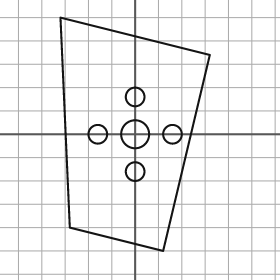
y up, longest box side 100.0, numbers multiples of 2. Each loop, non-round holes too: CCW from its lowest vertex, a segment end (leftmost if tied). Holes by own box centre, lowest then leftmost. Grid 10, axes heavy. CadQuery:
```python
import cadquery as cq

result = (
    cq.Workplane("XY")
    .moveTo(12.0, -50.0)
    .lineTo(32.0, 34.0)
    .lineTo(-32.0, 50.0)
    .lineTo(-28.0, -40.0)
    .close()
    .moveTo(0.0, -16.0)
    .circle(4.0)
    .moveTo(-16.0, 0.0)
    .circle(4.0)
    .moveTo(0.0, 0.0)
    .circle(6.0)
    .moveTo(16.0, 0.0)
    .circle(4.0)
    .moveTo(0.0, 16.0)
    .circle(4.0)
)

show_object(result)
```